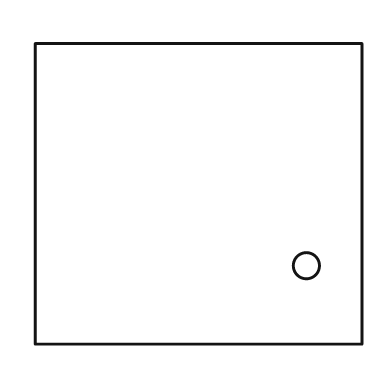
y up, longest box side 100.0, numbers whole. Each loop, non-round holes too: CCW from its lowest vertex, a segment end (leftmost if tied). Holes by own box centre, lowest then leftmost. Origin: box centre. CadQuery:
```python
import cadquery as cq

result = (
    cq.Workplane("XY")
    .moveTo(-50.0, -46.0)
    .lineTo(50.0, -46.0)
    .lineTo(50.0, 46.0)
    .lineTo(-50.0, 46.0)
    .close()
    .moveTo(33.0, -22.0)
    .circle(4.0)
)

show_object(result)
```